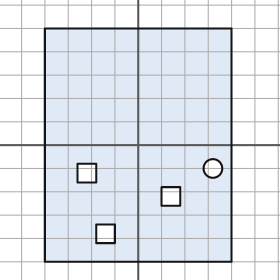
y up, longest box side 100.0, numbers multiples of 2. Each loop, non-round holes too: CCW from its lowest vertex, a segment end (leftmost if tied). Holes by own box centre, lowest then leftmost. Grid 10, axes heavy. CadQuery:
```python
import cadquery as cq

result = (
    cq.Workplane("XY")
    .moveTo(-40.0, -50.0)
    .lineTo(40.0, -50.0)
    .lineTo(40.0, 50.0)
    .lineTo(-40.0, 50.0)
    .close()
    .moveTo(-18.0, -42.0)
    .lineTo(-10.0, -42.0)
    .lineTo(-10.0, -34.0)
    .lineTo(-18.0, -34.0)
    .close()
    .moveTo(10.0, -26.0)
    .lineTo(18.0, -26.0)
    .lineTo(18.0, -18.0)
    .lineTo(10.0, -18.0)
    .close()
    .moveTo(-26.0, -16.0)
    .lineTo(-18.0, -16.0)
    .lineTo(-18.0, -8.0)
    .lineTo(-26.0, -8.0)
    .close()
    .moveTo(32.0, -10.0)
    .circle(4.0)
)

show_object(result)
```